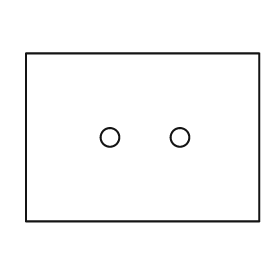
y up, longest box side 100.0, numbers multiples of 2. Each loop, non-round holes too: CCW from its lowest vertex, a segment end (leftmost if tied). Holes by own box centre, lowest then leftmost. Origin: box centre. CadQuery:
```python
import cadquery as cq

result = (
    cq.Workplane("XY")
    .moveTo(-50.0, -36.0)
    .lineTo(50.0, -36.0)
    .lineTo(50.0, 36.0)
    .lineTo(-50.0, 36.0)
    .close()
    .moveTo(-14.0, 0.0)
    .circle(4.0)
    .moveTo(16.0, 0.0)
    .circle(4.0)
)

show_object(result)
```